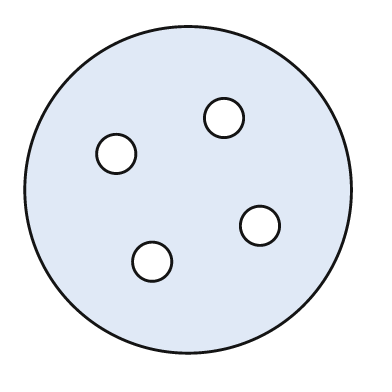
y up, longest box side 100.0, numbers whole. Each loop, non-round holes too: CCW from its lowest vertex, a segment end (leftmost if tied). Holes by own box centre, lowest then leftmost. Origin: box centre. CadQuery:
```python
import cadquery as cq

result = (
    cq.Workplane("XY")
    .moveTo(0.0, 0.0)
    .circle(50.0)
    .moveTo(-11.0, -22.0)
    .circle(6.0)
    .moveTo(22.0, -11.0)
    .circle(6.0)
    .moveTo(-22.0, 11.0)
    .circle(6.0)
    .moveTo(11.0, 22.0)
    .circle(6.0)
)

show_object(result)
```